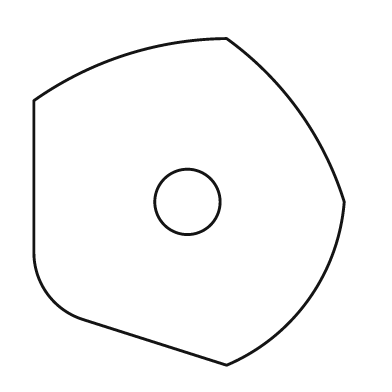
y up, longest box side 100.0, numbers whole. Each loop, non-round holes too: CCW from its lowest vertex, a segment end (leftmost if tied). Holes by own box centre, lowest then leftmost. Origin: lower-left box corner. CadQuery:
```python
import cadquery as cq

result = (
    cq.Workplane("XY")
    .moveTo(59.0, 0.0)
    .threePointArc((84.0, 20.0), (95.0, 50.0))
    .threePointArc((81.0, 78.0), (59.0, 100.0))
    .threePointArc((28.0, 95.0), (0.0, 81.0))
    .lineTo(0.0, 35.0)
    .threePointArc((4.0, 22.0), (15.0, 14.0))
    .close()
    .moveTo(47.0, 50.0)
    .circle(10.0)
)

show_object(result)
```